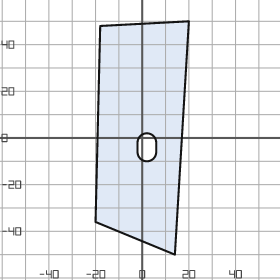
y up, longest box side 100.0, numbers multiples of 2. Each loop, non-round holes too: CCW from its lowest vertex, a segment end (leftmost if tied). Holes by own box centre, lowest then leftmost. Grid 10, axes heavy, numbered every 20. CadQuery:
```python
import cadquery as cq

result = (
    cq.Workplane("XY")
    .moveTo(14.0, -50.0)
    .lineTo(20.0, 50.0)
    .lineTo(-18.0, 48.0)
    .lineTo(-20.0, -36.0)
    .close()
    .moveTo(-2.0, -6.0)
    .threePointArc((2.0, -10.0), (6.0, -6.0))
    .lineTo(6.0, -2.0)
    .threePointArc((2.0, 2.0), (-2.0, -2.0))
    .close()
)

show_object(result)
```